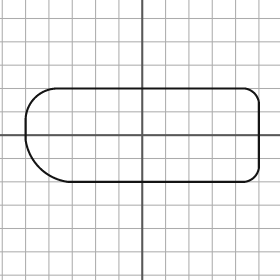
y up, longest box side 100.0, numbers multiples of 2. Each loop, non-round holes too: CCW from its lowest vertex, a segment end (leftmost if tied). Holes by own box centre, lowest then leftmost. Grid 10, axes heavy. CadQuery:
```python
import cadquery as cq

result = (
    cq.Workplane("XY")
    .moveTo(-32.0, -20.0)
    .lineTo(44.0, -20.0)
    .threePointArc((48.0, -18.0), (50.0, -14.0))
    .lineTo(50.0, 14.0)
    .threePointArc((48.0, 18.0), (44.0, 20.0))
    .lineTo(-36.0, 20.0)
    .threePointArc((-46.0, 16.0), (-50.0, 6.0))
    .lineTo(-50.0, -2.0)
    .threePointArc((-44.0, -14.0), (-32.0, -20.0))
    .close()
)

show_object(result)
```